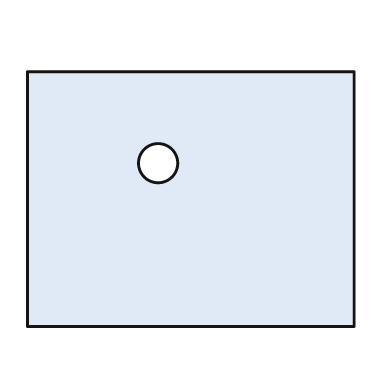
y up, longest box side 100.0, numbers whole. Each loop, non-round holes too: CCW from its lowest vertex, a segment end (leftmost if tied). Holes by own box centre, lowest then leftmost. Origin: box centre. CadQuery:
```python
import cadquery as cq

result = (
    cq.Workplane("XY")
    .moveTo(-50.0, -39.0)
    .lineTo(50.0, -39.0)
    .lineTo(50.0, 39.0)
    .lineTo(-50.0, 39.0)
    .close()
    .moveTo(-10.0, 11.0)
    .circle(6.0)
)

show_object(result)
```